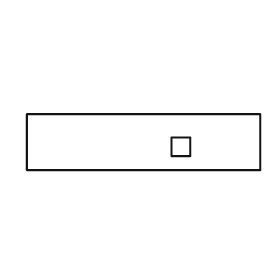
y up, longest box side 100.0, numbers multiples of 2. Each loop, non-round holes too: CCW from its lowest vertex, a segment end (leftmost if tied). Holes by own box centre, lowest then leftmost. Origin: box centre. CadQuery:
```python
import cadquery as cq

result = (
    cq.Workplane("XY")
    .moveTo(-50.0, -12.0)
    .lineTo(50.0, -12.0)
    .lineTo(50.0, 12.0)
    .lineTo(-50.0, 12.0)
    .close()
    .moveTo(12.0, -6.0)
    .lineTo(20.0, -6.0)
    .lineTo(20.0, 2.0)
    .lineTo(12.0, 2.0)
    .close()
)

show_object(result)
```